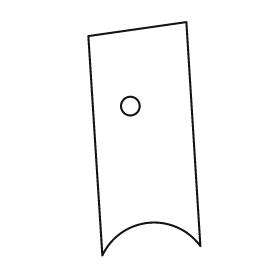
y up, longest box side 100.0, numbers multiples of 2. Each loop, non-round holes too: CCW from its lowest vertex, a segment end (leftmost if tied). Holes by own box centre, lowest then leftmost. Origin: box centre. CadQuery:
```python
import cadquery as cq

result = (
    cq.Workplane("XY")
    .moveTo(-18.0, -50.0)
    .threePointArc((2.0, -36.0), (24.0, -46.0))
    .lineTo(18.0, 50.0)
    .lineTo(-24.0, 44.0)
    .close()
    .moveTo(-6.0, 14.0)
    .circle(4.0)
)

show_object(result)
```